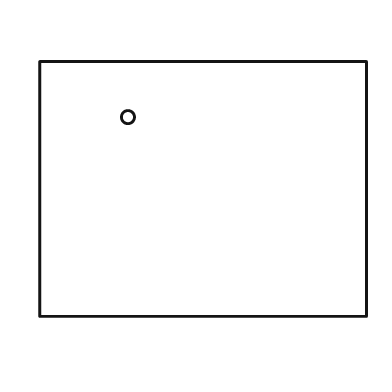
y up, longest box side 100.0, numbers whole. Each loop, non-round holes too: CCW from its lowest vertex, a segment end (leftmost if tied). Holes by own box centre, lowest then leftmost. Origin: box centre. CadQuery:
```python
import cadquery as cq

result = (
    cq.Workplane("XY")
    .moveTo(-50.0, -39.0)
    .lineTo(50.0, -39.0)
    .lineTo(50.0, 39.0)
    .lineTo(-50.0, 39.0)
    .close()
    .moveTo(-23.0, 22.0)
    .circle(2.0)
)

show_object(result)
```